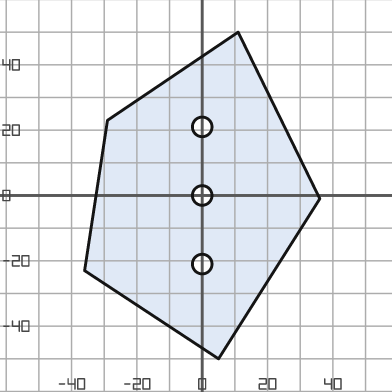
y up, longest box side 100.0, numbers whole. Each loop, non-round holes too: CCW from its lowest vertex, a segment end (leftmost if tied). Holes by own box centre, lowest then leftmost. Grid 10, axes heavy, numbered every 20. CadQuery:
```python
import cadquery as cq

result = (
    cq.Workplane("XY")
    .moveTo(5.0, -50.0)
    .lineTo(36.0, -1.0)
    .lineTo(11.0, 50.0)
    .lineTo(-29.0, 23.0)
    .lineTo(-36.0, -23.0)
    .close()
    .moveTo(0.0, -21.0)
    .circle(3.0)
    .moveTo(0.0, 0.0)
    .circle(3.0)
    .moveTo(0.0, 21.0)
    .circle(3.0)
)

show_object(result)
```